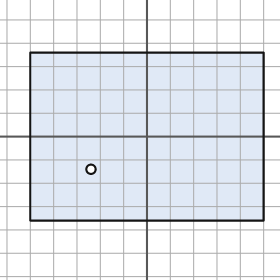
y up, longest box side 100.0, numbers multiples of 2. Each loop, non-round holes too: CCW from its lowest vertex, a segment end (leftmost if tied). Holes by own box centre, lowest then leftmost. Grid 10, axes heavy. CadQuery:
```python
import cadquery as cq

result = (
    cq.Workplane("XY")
    .moveTo(-50.0, -36.0)
    .lineTo(50.0, -36.0)
    .lineTo(50.0, 36.0)
    .lineTo(-50.0, 36.0)
    .close()
    .moveTo(-24.0, -14.0)
    .circle(2.0)
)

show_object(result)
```